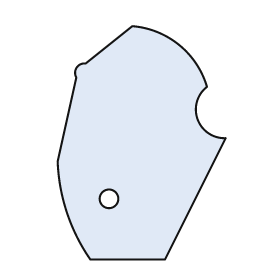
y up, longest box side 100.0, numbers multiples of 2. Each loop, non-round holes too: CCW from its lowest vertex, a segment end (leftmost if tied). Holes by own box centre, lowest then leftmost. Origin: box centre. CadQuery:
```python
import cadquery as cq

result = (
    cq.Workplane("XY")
    .moveTo(-22.0, -50.0)
    .lineTo(10.0, -50.0)
    .lineTo(36.0, 2.0)
    .threePointArc((24.0, 10.0), (28.0, 24.0))
    .threePointArc((16.0, 42.0), (-4.0, 50.0))
    .lineTo(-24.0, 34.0)
    .threePointArc((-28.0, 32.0), (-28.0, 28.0))
    .lineTo(-36.0, -8.0)
    .threePointArc((-32.0, -30.0), (-22.0, -50.0))
    .close()
    .moveTo(-14.0, -24.0)
    .circle(4.0)
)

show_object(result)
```